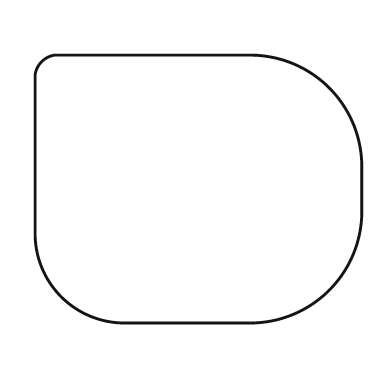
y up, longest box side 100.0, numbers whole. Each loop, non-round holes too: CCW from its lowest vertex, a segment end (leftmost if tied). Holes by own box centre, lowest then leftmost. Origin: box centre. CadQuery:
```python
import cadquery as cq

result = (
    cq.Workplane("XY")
    .moveTo(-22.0, -41.0)
    .lineTo(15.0, -41.0)
    .threePointArc((40.0, -31.0), (50.0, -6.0))
    .lineTo(50.0, 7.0)
    .threePointArc((40.0, 31.0), (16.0, 41.0))
    .lineTo(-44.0, 41.0)
    .threePointArc((-48.0, 39.0), (-50.0, 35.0))
    .lineTo(-50.0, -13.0)
    .threePointArc((-42.0, -33.0), (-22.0, -41.0))
    .close()
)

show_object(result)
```